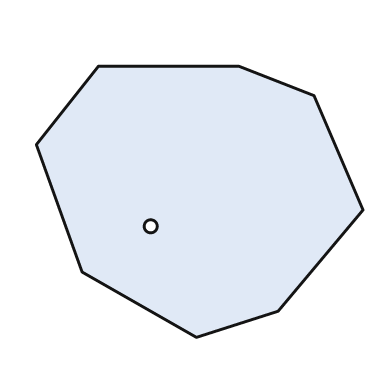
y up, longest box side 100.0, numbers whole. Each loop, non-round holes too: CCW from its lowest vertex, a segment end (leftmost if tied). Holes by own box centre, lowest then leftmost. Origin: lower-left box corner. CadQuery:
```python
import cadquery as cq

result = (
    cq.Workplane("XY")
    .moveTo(49.0, 0.0)
    .lineTo(74.0, 8.0)
    .lineTo(100.0, 39.0)
    .lineTo(85.0, 74.0)
    .lineTo(62.0, 83.0)
    .lineTo(19.0, 83.0)
    .lineTo(0.0, 59.0)
    .lineTo(14.0, 20.0)
    .close()
    .moveTo(35.0, 34.0)
    .circle(2.0)
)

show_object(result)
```